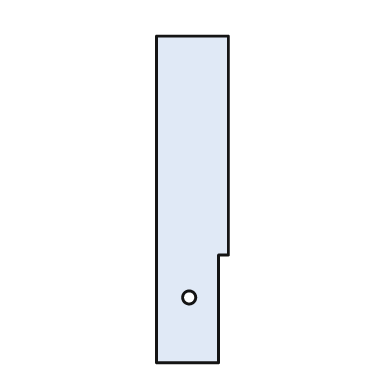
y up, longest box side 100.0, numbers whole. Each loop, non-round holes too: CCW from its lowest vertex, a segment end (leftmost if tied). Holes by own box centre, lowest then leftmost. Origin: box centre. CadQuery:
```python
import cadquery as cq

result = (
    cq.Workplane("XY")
    .moveTo(-11.0, -50.0)
    .lineTo(8.0, -50.0)
    .lineTo(8.0, -17.0)
    .lineTo(11.0, -17.0)
    .lineTo(11.0, 50.0)
    .lineTo(-11.0, 50.0)
    .close()
    .moveTo(-1.0, -30.0)
    .circle(2.0)
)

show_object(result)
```